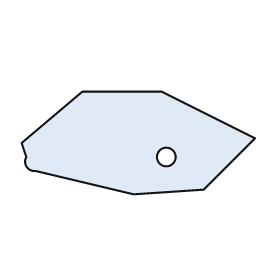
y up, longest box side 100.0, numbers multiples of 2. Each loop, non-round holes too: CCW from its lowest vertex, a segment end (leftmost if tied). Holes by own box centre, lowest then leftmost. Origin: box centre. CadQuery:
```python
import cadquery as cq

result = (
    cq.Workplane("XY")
    .moveTo(-2.0, -22.0)
    .lineTo(28.0, -20.0)
    .lineTo(50.0, 2.0)
    .lineTo(10.0, 22.0)
    .lineTo(-24.0, 22.0)
    .lineTo(-50.0, 0.0)
    .lineTo(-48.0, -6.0)
    .threePointArc((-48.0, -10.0), (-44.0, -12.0))
    .close()
    .moveTo(12.0, -6.0)
    .circle(4.0)
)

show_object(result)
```